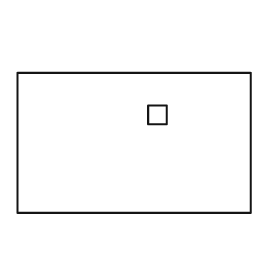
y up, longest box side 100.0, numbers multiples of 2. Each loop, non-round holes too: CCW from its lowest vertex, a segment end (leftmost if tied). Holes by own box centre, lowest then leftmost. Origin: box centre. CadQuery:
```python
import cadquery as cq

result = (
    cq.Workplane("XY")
    .moveTo(-50.0, -30.0)
    .lineTo(50.0, -30.0)
    .lineTo(50.0, 30.0)
    .lineTo(-50.0, 30.0)
    .close()
    .moveTo(6.0, 8.0)
    .lineTo(14.0, 8.0)
    .lineTo(14.0, 16.0)
    .lineTo(6.0, 16.0)
    .close()
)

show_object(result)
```